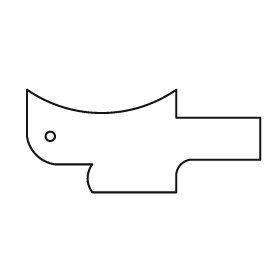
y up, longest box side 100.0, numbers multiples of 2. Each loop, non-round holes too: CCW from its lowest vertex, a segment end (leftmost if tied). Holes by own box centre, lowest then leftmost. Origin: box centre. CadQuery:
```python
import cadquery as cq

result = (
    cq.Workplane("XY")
    .moveTo(-22.0, -22.0)
    .lineTo(14.0, -22.0)
    .lineTo(14.0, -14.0)
    .threePointArc((16.0, -10.0), (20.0, -8.0))
    .lineTo(50.0, -8.0)
    .lineTo(50.0, 10.0)
    .lineTo(14.0, 10.0)
    .lineTo(14.0, 22.0)
    .threePointArc((-18.0, 12.0), (-50.0, 22.0))
    .lineTo(-50.0, 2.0)
    .threePointArc((-46.0, -6.0), (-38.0, -10.0))
    .lineTo(-22.0, -10.0)
    .threePointArc((-24.0, -16.0), (-22.0, -22.0))
    .close()
    .moveTo(-40.0, 2.0)
    .circle(2.0)
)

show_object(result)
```